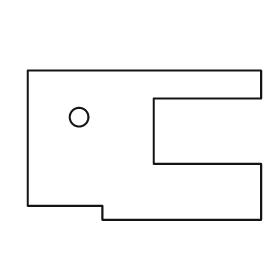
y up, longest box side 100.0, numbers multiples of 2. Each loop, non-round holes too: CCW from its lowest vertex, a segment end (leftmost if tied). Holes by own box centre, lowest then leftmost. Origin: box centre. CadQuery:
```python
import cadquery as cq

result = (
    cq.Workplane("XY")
    .moveTo(-18.0, -32.0)
    .lineTo(50.0, -32.0)
    .lineTo(50.0, -8.0)
    .lineTo(4.0, -8.0)
    .lineTo(4.0, 20.0)
    .lineTo(50.0, 20.0)
    .lineTo(50.0, 32.0)
    .lineTo(-50.0, 32.0)
    .lineTo(-50.0, -26.0)
    .lineTo(-18.0, -26.0)
    .close()
    .moveTo(-28.0, 12.0)
    .circle(4.0)
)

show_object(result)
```